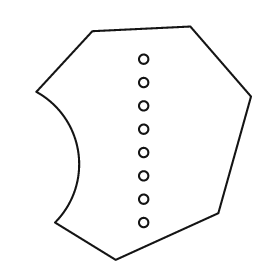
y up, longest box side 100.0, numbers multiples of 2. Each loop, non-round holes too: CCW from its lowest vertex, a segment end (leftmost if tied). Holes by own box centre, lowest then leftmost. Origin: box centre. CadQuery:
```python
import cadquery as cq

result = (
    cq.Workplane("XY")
    .moveTo(-12.0, -50.0)
    .lineTo(32.0, -30.0)
    .lineTo(46.0, 20.0)
    .lineTo(20.0, 50.0)
    .lineTo(-22.0, 48.0)
    .lineTo(-46.0, 22.0)
    .threePointArc((-28.0, -4.0), (-38.0, -34.0))
    .close()
    .moveTo(0.0, -34.0)
    .circle(2.0)
    .moveTo(0.0, -24.0)
    .circle(2.0)
    .moveTo(0.0, -14.0)
    .circle(2.0)
    .moveTo(0.0, -4.0)
    .circle(2.0)
    .moveTo(0.0, 6.0)
    .circle(2.0)
    .moveTo(0.0, 16.0)
    .circle(2.0)
    .moveTo(0.0, 26.0)
    .circle(2.0)
    .moveTo(0.0, 36.0)
    .circle(2.0)
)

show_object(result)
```